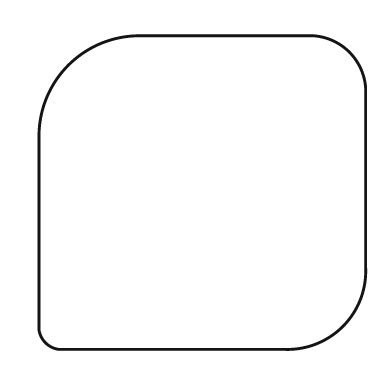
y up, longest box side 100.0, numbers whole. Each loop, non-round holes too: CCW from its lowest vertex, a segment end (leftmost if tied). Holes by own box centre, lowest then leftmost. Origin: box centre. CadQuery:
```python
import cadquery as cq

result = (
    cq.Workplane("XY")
    .moveTo(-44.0, -48.0)
    .lineTo(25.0, -48.0)
    .threePointArc((43.0, -41.0), (50.0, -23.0))
    .lineTo(50.0, 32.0)
    .threePointArc((45.0, 43.0), (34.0, 48.0))
    .lineTo(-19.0, 48.0)
    .threePointArc((-41.0, 39.0), (-50.0, 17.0))
    .lineTo(-50.0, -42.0)
    .threePointArc((-48.0, -46.0), (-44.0, -48.0))
    .close()
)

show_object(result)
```